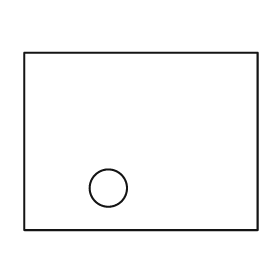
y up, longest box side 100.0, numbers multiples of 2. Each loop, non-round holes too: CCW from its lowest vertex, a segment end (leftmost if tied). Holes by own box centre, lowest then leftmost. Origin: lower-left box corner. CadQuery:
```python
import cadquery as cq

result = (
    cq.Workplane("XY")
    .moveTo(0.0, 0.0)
    .lineTo(100.0, 0.0)
    .lineTo(100.0, 76.0)
    .lineTo(0.0, 76.0)
    .close()
    .moveTo(36.0, 18.0)
    .circle(8.0)
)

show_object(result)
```